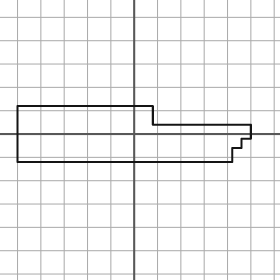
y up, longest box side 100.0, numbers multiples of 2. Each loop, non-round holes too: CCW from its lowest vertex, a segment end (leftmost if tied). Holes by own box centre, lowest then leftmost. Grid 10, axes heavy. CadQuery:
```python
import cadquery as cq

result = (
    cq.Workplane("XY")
    .moveTo(-50.0, -12.0)
    .lineTo(42.0, -12.0)
    .lineTo(42.0, -6.0)
    .lineTo(46.0, -6.0)
    .lineTo(46.0, -2.0)
    .lineTo(50.0, -2.0)
    .lineTo(50.0, 4.0)
    .lineTo(8.0, 4.0)
    .lineTo(8.0, 12.0)
    .lineTo(-50.0, 12.0)
    .close()
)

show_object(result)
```